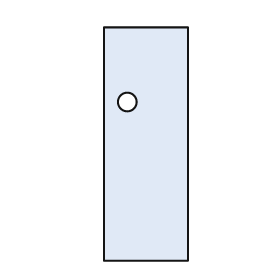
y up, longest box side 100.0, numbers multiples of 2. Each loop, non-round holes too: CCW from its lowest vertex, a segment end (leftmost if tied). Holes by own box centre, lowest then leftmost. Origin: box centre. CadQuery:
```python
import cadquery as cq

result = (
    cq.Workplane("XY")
    .moveTo(-18.0, -50.0)
    .lineTo(18.0, -50.0)
    .lineTo(18.0, 50.0)
    .lineTo(-18.0, 50.0)
    .close()
    .moveTo(-8.0, 18.0)
    .circle(4.0)
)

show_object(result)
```